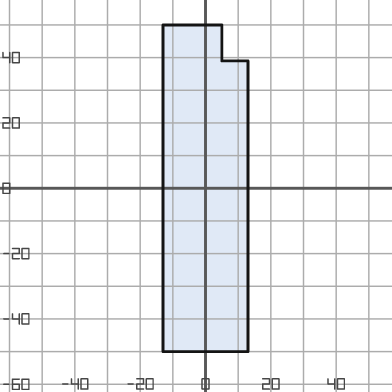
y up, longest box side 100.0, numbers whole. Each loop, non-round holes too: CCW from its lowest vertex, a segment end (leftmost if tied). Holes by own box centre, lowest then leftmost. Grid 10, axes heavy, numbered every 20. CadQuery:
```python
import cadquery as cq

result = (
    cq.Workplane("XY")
    .moveTo(-13.0, -50.0)
    .lineTo(13.0, -50.0)
    .lineTo(13.0, 39.0)
    .lineTo(5.0, 39.0)
    .lineTo(5.0, 50.0)
    .lineTo(-13.0, 50.0)
    .close()
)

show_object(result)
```